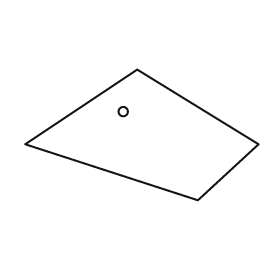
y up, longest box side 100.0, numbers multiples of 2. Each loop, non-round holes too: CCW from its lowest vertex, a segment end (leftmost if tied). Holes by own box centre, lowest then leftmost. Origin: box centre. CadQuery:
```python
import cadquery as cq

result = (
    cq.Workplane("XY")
    .moveTo(24.0, -28.0)
    .lineTo(50.0, -4.0)
    .lineTo(-2.0, 28.0)
    .lineTo(-50.0, -4.0)
    .close()
    .moveTo(-8.0, 10.0)
    .circle(2.0)
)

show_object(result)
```